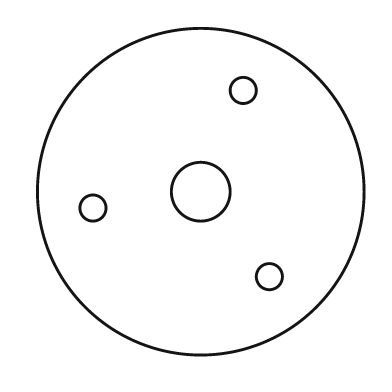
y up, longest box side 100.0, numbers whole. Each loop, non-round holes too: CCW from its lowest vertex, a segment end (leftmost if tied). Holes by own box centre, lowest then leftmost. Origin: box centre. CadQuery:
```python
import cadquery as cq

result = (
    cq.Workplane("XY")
    .moveTo(0.0, 0.0)
    .circle(50.0)
    .moveTo(21.0, -26.0)
    .circle(4.0)
    .moveTo(-33.0, -5.0)
    .circle(4.0)
    .moveTo(0.0, 0.0)
    .circle(9.0)
    .moveTo(13.0, 31.0)
    .circle(4.0)
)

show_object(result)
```